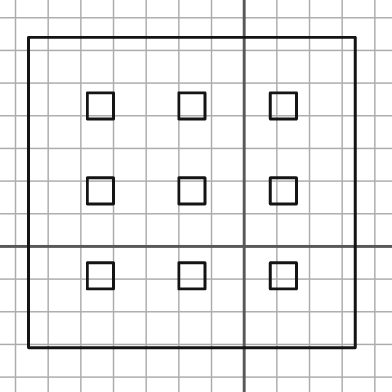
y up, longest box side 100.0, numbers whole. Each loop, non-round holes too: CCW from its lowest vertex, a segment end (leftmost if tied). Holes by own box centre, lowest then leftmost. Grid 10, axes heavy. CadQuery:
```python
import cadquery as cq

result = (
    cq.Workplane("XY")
    .moveTo(-66.0, -31.0)
    .lineTo(34.0, -31.0)
    .lineTo(34.0, 64.0)
    .lineTo(-66.0, 64.0)
    .close()
    .moveTo(-48.0, -13.0)
    .lineTo(-40.0, -13.0)
    .lineTo(-40.0, -5.0)
    .lineTo(-48.0, -5.0)
    .close()
    .moveTo(-20.0, -13.0)
    .lineTo(-12.0, -13.0)
    .lineTo(-12.0, -5.0)
    .lineTo(-20.0, -5.0)
    .close()
    .moveTo(8.0, -13.0)
    .lineTo(16.0, -13.0)
    .lineTo(16.0, -5.0)
    .lineTo(8.0, -5.0)
    .close()
    .moveTo(-48.0, 13.0)
    .lineTo(-40.0, 13.0)
    .lineTo(-40.0, 21.0)
    .lineTo(-48.0, 21.0)
    .close()
    .moveTo(-20.0, 13.0)
    .lineTo(-12.0, 13.0)
    .lineTo(-12.0, 21.0)
    .lineTo(-20.0, 21.0)
    .close()
    .moveTo(8.0, 13.0)
    .lineTo(16.0, 13.0)
    .lineTo(16.0, 21.0)
    .lineTo(8.0, 21.0)
    .close()
    .moveTo(-48.0, 39.0)
    .lineTo(-40.0, 39.0)
    .lineTo(-40.0, 47.0)
    .lineTo(-48.0, 47.0)
    .close()
    .moveTo(-20.0, 39.0)
    .lineTo(-12.0, 39.0)
    .lineTo(-12.0, 47.0)
    .lineTo(-20.0, 47.0)
    .close()
    .moveTo(8.0, 39.0)
    .lineTo(16.0, 39.0)
    .lineTo(16.0, 47.0)
    .lineTo(8.0, 47.0)
    .close()
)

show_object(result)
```